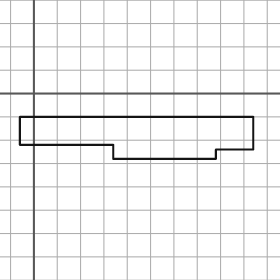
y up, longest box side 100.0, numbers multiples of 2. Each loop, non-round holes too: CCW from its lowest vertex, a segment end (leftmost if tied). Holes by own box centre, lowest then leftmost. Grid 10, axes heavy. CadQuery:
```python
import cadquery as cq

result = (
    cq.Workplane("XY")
    .moveTo(34.0, -28.0)
    .lineTo(78.0, -28.0)
    .lineTo(78.0, -24.0)
    .lineTo(94.0, -24.0)
    .lineTo(94.0, -10.0)
    .lineTo(-6.0, -10.0)
    .lineTo(-6.0, -22.0)
    .lineTo(34.0, -22.0)
    .close()
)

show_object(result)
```